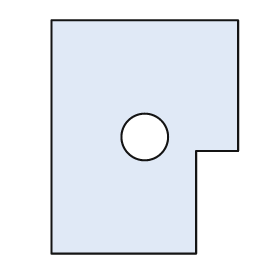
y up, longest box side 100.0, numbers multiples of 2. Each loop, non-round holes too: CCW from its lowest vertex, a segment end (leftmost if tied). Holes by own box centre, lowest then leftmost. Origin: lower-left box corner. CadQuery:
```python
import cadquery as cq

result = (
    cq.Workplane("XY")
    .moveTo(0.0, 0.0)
    .lineTo(62.0, 0.0)
    .lineTo(62.0, 44.0)
    .lineTo(80.0, 44.0)
    .lineTo(80.0, 100.0)
    .lineTo(0.0, 100.0)
    .close()
    .moveTo(40.0, 50.0)
    .circle(10.0)
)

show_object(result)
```